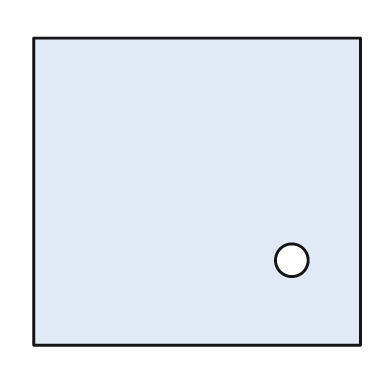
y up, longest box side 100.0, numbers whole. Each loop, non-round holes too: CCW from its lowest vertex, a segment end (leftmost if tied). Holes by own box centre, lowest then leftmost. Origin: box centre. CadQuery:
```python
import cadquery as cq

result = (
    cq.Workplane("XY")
    .moveTo(-50.0, -47.0)
    .lineTo(50.0, -47.0)
    .lineTo(50.0, 47.0)
    .lineTo(-50.0, 47.0)
    .close()
    .moveTo(29.0, -21.0)
    .circle(5.0)
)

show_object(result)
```